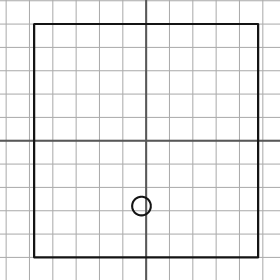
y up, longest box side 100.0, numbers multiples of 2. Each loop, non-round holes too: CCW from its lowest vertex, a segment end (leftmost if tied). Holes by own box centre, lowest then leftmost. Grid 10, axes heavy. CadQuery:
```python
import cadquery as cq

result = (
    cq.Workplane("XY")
    .moveTo(-48.0, -50.0)
    .lineTo(48.0, -50.0)
    .lineTo(48.0, 50.0)
    .lineTo(-48.0, 50.0)
    .close()
    .moveTo(-2.0, -28.0)
    .circle(4.0)
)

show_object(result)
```